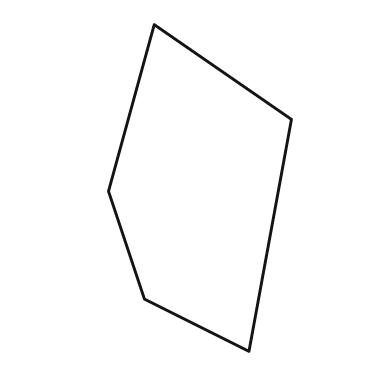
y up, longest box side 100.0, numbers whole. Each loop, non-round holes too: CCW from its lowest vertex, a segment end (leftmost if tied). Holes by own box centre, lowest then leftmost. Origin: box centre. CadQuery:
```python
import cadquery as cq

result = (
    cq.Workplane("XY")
    .moveTo(15.0, -50.0)
    .lineTo(28.0, 21.0)
    .lineTo(-14.0, 50.0)
    .lineTo(-28.0, -1.0)
    .lineTo(-17.0, -34.0)
    .close()
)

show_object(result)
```